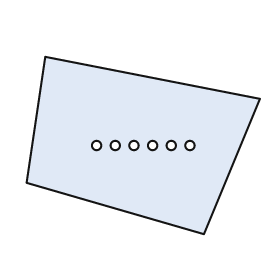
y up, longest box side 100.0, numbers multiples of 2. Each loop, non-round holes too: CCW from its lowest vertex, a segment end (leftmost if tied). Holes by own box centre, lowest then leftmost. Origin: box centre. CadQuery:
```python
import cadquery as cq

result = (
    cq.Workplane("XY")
    .moveTo(26.0, -38.0)
    .lineTo(50.0, 20.0)
    .lineTo(-42.0, 38.0)
    .lineTo(-50.0, -16.0)
    .close()
    .moveTo(-20.0, 0.0)
    .circle(2.0)
    .moveTo(-12.0, 0.0)
    .circle(2.0)
    .moveTo(-4.0, 0.0)
    .circle(2.0)
    .moveTo(4.0, 0.0)
    .circle(2.0)
    .moveTo(12.0, 0.0)
    .circle(2.0)
    .moveTo(20.0, 0.0)
    .circle(2.0)
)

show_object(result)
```